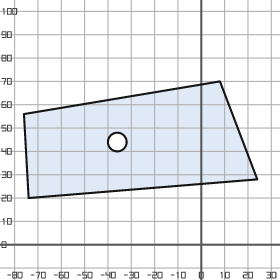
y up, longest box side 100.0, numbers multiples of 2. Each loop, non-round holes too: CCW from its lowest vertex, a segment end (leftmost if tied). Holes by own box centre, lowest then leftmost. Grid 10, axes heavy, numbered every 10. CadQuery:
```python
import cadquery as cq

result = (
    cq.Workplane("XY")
    .moveTo(-74.0, 20.0)
    .lineTo(24.0, 28.0)
    .lineTo(8.0, 70.0)
    .lineTo(-76.0, 56.0)
    .close()
    .moveTo(-36.0, 44.0)
    .circle(4.0)
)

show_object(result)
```